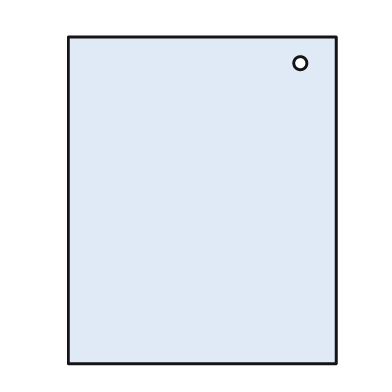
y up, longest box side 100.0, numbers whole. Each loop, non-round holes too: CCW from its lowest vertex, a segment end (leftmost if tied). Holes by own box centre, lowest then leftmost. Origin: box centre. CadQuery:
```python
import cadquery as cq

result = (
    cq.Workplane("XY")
    .moveTo(-41.0, -50.0)
    .lineTo(41.0, -50.0)
    .lineTo(41.0, 50.0)
    .lineTo(-41.0, 50.0)
    .close()
    .moveTo(30.0, 42.0)
    .circle(2.0)
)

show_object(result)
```